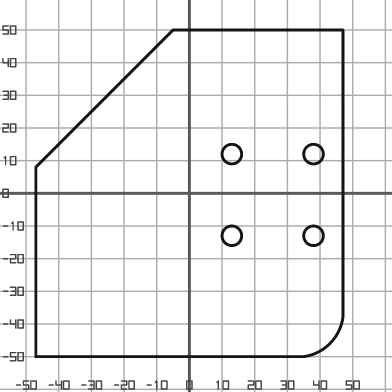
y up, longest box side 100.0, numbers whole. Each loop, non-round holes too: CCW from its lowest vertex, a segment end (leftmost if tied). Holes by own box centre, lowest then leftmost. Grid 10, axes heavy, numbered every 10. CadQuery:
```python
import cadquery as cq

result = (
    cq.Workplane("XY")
    .moveTo(-47.0, -50.0)
    .lineTo(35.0, -50.0)
    .threePointArc((43.0, -46.0), (47.0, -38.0))
    .lineTo(47.0, 50.0)
    .lineTo(-5.0, 50.0)
    .lineTo(-47.0, 8.0)
    .close()
    .moveTo(13.0, -13.0)
    .circle(3.0)
    .moveTo(38.0, -13.0)
    .circle(3.0)
    .moveTo(13.0, 12.0)
    .circle(3.0)
    .moveTo(38.0, 12.0)
    .circle(3.0)
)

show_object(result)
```